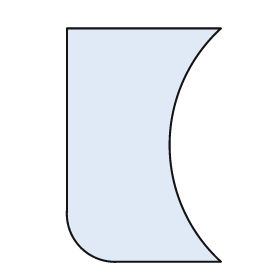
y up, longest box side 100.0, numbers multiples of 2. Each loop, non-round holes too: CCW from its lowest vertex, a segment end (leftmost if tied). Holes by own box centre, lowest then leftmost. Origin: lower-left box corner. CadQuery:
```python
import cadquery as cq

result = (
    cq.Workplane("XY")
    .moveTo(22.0, 0.0)
    .lineTo(66.0, 0.0)
    .threePointArc((44.0, 50.0), (66.0, 100.0))
    .lineTo(0.0, 100.0)
    .lineTo(0.0, 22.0)
    .threePointArc((6.0, 6.0), (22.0, 0.0))
    .close()
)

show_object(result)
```